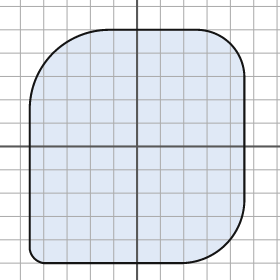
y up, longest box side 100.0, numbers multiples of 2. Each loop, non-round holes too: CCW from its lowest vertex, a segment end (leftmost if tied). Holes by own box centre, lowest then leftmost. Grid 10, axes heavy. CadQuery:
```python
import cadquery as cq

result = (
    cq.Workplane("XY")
    .moveTo(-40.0, -50.0)
    .lineTo(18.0, -50.0)
    .threePointArc((38.0, -42.0), (46.0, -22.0))
    .lineTo(46.0, 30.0)
    .threePointArc((40.0, 44.0), (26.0, 50.0))
    .lineTo(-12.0, 50.0)
    .threePointArc((-36.0, 40.0), (-46.0, 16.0))
    .lineTo(-46.0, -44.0)
    .threePointArc((-44.0, -48.0), (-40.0, -50.0))
    .close()
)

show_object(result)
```